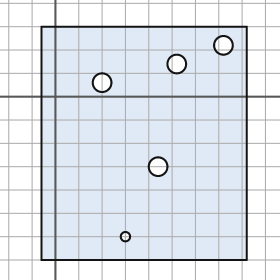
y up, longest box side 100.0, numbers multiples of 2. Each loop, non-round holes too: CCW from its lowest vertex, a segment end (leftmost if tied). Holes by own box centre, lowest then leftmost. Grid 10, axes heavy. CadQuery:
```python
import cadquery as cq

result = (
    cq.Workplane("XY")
    .moveTo(-6.0, -70.0)
    .lineTo(82.0, -70.0)
    .lineTo(82.0, 30.0)
    .lineTo(-6.0, 30.0)
    .close()
    .moveTo(30.0, -60.0)
    .circle(2.0)
    .moveTo(44.0, -30.0)
    .circle(4.0)
    .moveTo(20.0, 6.0)
    .circle(4.0)
    .moveTo(52.0, 14.0)
    .circle(4.0)
    .moveTo(72.0, 22.0)
    .circle(4.0)
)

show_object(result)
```